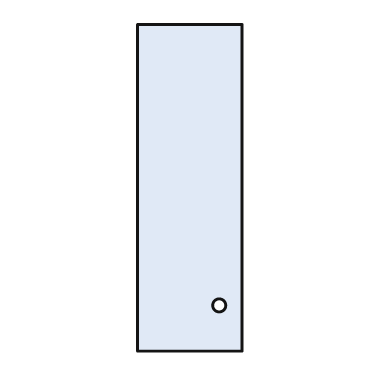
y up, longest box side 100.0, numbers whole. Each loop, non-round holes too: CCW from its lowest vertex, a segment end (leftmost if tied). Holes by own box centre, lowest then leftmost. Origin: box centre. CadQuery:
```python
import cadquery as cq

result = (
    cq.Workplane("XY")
    .moveTo(-16.0, -50.0)
    .lineTo(16.0, -50.0)
    .lineTo(16.0, 50.0)
    .lineTo(-16.0, 50.0)
    .close()
    .moveTo(9.0, -36.0)
    .circle(2.0)
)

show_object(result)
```